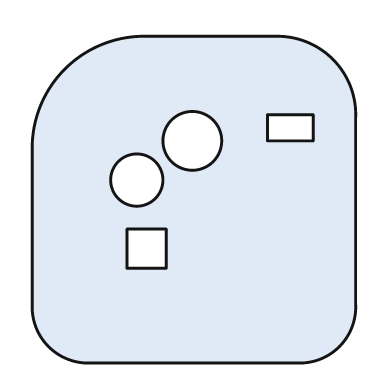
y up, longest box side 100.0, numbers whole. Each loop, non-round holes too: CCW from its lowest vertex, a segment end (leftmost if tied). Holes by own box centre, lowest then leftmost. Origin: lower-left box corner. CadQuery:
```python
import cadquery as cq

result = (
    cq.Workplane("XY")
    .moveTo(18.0, 0.0)
    .lineTo(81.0, 0.0)
    .threePointArc((94.0, 5.0), (99.0, 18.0))
    .lineTo(99.0, 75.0)
    .threePointArc((92.0, 93.0), (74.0, 100.0))
    .lineTo(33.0, 100.0)
    .threePointArc((10.0, 90.0), (0.0, 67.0))
    .lineTo(0.0, 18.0)
    .threePointArc((5.0, 5.0), (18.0, 0.0))
    .close()
    .moveTo(29.0, 29.0)
    .lineTo(41.0, 29.0)
    .lineTo(41.0, 41.0)
    .lineTo(29.0, 41.0)
    .close()
    .moveTo(32.0, 56.0)
    .circle(8.0)
    .moveTo(49.0, 68.0)
    .circle(9.0)
    .moveTo(72.0, 68.0)
    .lineTo(86.0, 68.0)
    .lineTo(86.0, 76.0)
    .lineTo(72.0, 76.0)
    .close()
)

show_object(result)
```